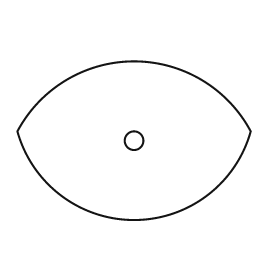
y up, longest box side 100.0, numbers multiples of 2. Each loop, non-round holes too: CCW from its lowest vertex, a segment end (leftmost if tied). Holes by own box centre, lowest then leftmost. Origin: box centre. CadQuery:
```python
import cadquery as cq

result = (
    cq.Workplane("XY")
    .moveTo(-50.0, 4.0)
    .threePointArc((0.0, -34.0), (50.0, 4.0))
    .threePointArc((0.0, 34.0), (-50.0, 4.0))
    .close()
    .moveTo(0.0, 0.0)
    .circle(4.0)
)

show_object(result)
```